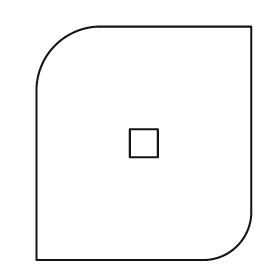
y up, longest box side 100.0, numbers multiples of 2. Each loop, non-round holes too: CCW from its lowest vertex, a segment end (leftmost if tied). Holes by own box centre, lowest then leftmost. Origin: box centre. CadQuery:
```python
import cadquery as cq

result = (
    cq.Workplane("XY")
    .moveTo(-46.0, -50.0)
    .lineTo(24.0, -50.0)
    .threePointArc((40.0, -44.0), (46.0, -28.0))
    .lineTo(46.0, 50.0)
    .lineTo(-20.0, 50.0)
    .threePointArc((-38.0, 42.0), (-46.0, 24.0))
    .close()
    .moveTo(-6.0, -6.0)
    .lineTo(6.0, -6.0)
    .lineTo(6.0, 6.0)
    .lineTo(-6.0, 6.0)
    .close()
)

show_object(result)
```